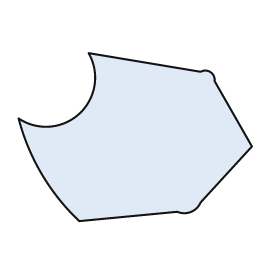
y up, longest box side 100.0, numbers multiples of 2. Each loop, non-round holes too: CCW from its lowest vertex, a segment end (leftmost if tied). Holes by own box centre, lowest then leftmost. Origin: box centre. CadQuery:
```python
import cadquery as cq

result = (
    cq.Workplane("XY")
    .moveTo(-24.0, -36.0)
    .lineTo(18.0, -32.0)
    .threePointArc((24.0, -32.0), (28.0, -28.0))
    .lineTo(50.0, -4.0)
    .lineTo(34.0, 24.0)
    .threePointArc((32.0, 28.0), (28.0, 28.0))
    .lineTo(-20.0, 36.0)
    .threePointArc((-24.0, 10.0), (-50.0, 8.0))
    .threePointArc((-40.0, -16.0), (-24.0, -36.0))
    .close()
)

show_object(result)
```